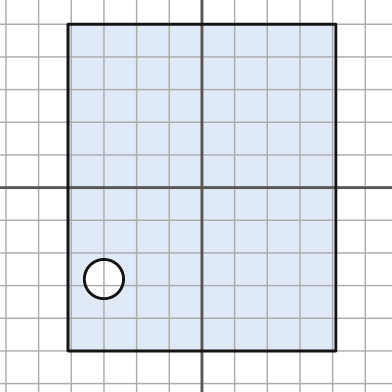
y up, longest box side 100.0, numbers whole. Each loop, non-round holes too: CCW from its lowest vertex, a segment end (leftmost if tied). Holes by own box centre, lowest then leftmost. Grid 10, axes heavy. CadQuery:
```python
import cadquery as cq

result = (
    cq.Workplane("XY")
    .moveTo(-41.0, -50.0)
    .lineTo(41.0, -50.0)
    .lineTo(41.0, 50.0)
    .lineTo(-41.0, 50.0)
    .close()
    .moveTo(-30.0, -28.0)
    .circle(6.0)
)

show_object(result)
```